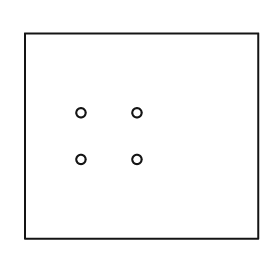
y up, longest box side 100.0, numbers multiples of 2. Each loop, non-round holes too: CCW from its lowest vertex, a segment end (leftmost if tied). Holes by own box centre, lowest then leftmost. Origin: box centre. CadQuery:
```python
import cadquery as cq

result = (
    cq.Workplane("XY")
    .moveTo(-50.0, -44.0)
    .lineTo(50.0, -44.0)
    .lineTo(50.0, 44.0)
    .lineTo(-50.0, 44.0)
    .close()
    .moveTo(-26.0, -10.0)
    .circle(2.0)
    .moveTo(-2.0, -10.0)
    .circle(2.0)
    .moveTo(-26.0, 10.0)
    .circle(2.0)
    .moveTo(-2.0, 10.0)
    .circle(2.0)
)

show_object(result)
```